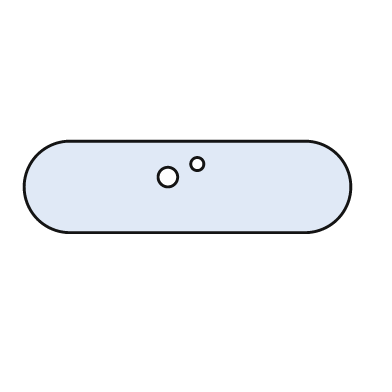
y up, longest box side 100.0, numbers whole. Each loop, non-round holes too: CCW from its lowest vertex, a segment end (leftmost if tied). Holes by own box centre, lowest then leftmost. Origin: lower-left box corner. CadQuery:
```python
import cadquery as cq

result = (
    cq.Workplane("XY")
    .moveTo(14.0, 0.0)
    .lineTo(86.0, 0.0)
    .threePointArc((100.0, 14.0), (86.0, 28.0))
    .lineTo(14.0, 28.0)
    .threePointArc((0.0, 14.0), (14.0, 0.0))
    .close()
    .moveTo(44.0, 17.0)
    .circle(3.0)
    .moveTo(53.0, 21.0)
    .circle(2.0)
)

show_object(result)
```